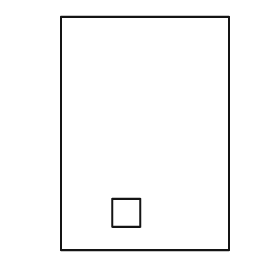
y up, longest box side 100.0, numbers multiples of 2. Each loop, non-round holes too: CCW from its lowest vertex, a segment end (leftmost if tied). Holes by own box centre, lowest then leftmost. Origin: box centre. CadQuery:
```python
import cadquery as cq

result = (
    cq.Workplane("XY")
    .moveTo(-36.0, -50.0)
    .lineTo(36.0, -50.0)
    .lineTo(36.0, 50.0)
    .lineTo(-36.0, 50.0)
    .close()
    .moveTo(-14.0, -40.0)
    .lineTo(-2.0, -40.0)
    .lineTo(-2.0, -28.0)
    .lineTo(-14.0, -28.0)
    .close()
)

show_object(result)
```